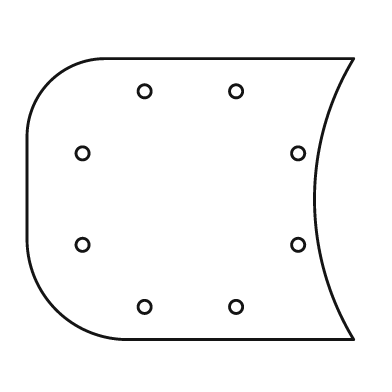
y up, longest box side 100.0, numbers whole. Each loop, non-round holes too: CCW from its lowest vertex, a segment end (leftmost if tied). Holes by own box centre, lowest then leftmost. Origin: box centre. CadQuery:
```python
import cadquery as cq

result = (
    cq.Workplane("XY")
    .moveTo(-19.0, -43.0)
    .lineTo(50.0, -43.0)
    .threePointArc((38.0, 0.0), (50.0, 43.0))
    .lineTo(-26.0, 43.0)
    .threePointArc((-43.0, 36.0), (-50.0, 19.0))
    .lineTo(-50.0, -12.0)
    .threePointArc((-41.0, -34.0), (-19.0, -43.0))
    .close()
    .moveTo(-14.0, -33.0)
    .circle(2.0)
    .moveTo(14.0, -33.0)
    .circle(2.0)
    .moveTo(-33.0, -14.0)
    .circle(2.0)
    .moveTo(33.0, -14.0)
    .circle(2.0)
    .moveTo(-33.0, 14.0)
    .circle(2.0)
    .moveTo(33.0, 14.0)
    .circle(2.0)
    .moveTo(-14.0, 33.0)
    .circle(2.0)
    .moveTo(14.0, 33.0)
    .circle(2.0)
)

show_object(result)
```